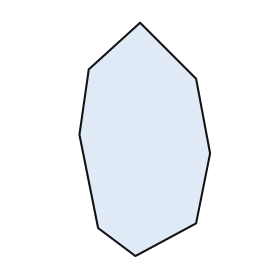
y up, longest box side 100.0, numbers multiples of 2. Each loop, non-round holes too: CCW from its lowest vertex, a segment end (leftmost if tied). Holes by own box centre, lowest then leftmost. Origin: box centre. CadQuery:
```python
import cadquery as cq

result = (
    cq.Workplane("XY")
    .moveTo(-4.0, -50.0)
    .lineTo(22.0, -36.0)
    .lineTo(28.0, -6.0)
    .lineTo(22.0, 26.0)
    .lineTo(-2.0, 50.0)
    .lineTo(-24.0, 30.0)
    .lineTo(-28.0, 2.0)
    .lineTo(-20.0, -38.0)
    .close()
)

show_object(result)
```